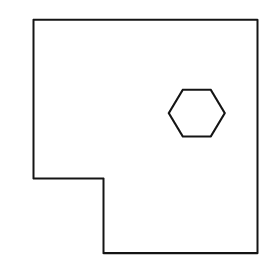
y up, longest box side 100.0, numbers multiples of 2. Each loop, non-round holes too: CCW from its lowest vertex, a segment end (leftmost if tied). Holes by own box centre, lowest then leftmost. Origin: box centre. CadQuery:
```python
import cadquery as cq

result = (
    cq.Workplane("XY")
    .moveTo(-18.0, -50.0)
    .lineTo(48.0, -50.0)
    .lineTo(48.0, 50.0)
    .lineTo(-48.0, 50.0)
    .lineTo(-48.0, -18.0)
    .lineTo(-18.0, -18.0)
    .close()
    .moveTo(16.0, 0.0)
    .lineTo(28.0, 0.0)
    .lineTo(34.0, 10.0)
    .lineTo(28.0, 20.0)
    .lineTo(16.0, 20.0)
    .lineTo(10.0, 10.0)
    .close()
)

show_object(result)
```